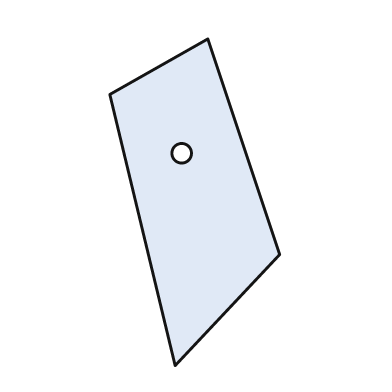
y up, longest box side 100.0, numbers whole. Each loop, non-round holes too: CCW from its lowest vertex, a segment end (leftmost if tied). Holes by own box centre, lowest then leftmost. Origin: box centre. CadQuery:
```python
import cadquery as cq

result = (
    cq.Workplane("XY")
    .moveTo(-6.0, -50.0)
    .lineTo(26.0, -16.0)
    .lineTo(4.0, 50.0)
    .lineTo(-26.0, 33.0)
    .close()
    .moveTo(-4.0, 15.0)
    .circle(3.0)
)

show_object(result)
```